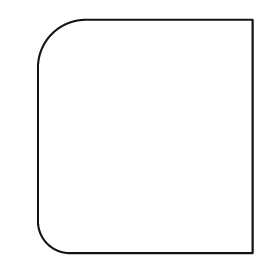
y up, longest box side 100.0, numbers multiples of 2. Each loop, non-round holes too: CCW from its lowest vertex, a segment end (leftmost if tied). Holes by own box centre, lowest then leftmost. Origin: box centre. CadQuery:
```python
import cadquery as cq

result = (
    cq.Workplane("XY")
    .moveTo(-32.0, -50.0)
    .lineTo(46.0, -50.0)
    .lineTo(46.0, 50.0)
    .lineTo(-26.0, 50.0)
    .threePointArc((-40.0, 44.0), (-46.0, 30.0))
    .lineTo(-46.0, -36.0)
    .threePointArc((-42.0, -46.0), (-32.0, -50.0))
    .close()
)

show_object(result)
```